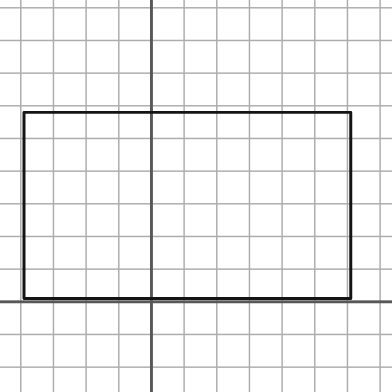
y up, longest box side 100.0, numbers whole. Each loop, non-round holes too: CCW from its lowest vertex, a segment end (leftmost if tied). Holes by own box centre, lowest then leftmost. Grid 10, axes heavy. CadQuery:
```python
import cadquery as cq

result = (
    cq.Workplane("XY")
    .moveTo(-39.0, 1.0)
    .lineTo(61.0, 1.0)
    .lineTo(61.0, 58.0)
    .lineTo(-39.0, 58.0)
    .close()
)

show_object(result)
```